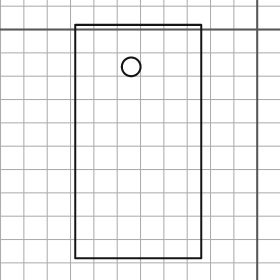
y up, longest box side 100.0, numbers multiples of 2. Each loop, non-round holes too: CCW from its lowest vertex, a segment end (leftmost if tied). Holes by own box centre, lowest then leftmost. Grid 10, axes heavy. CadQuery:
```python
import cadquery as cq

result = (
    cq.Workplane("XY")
    .moveTo(-78.0, -98.0)
    .lineTo(-24.0, -98.0)
    .lineTo(-24.0, 2.0)
    .lineTo(-78.0, 2.0)
    .close()
    .moveTo(-54.0, -16.0)
    .circle(4.0)
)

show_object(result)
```